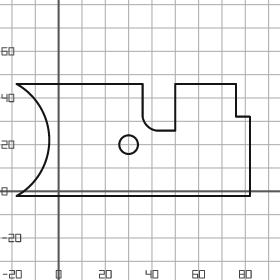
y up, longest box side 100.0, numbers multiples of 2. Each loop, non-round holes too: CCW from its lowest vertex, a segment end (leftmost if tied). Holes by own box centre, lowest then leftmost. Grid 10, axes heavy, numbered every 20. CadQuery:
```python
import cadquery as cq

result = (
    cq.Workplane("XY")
    .moveTo(-18.0, -2.0)
    .lineTo(82.0, -2.0)
    .lineTo(82.0, 32.0)
    .lineTo(76.0, 32.0)
    .lineTo(76.0, 46.0)
    .lineTo(50.0, 46.0)
    .lineTo(50.0, 26.0)
    .lineTo(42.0, 26.0)
    .threePointArc((38.0, 28.0), (36.0, 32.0))
    .lineTo(36.0, 46.0)
    .lineTo(-18.0, 46.0)
    .threePointArc((-4.0, 22.0), (-18.0, -2.0))
    .close()
    .moveTo(30.0, 20.0)
    .circle(4.0)
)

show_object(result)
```